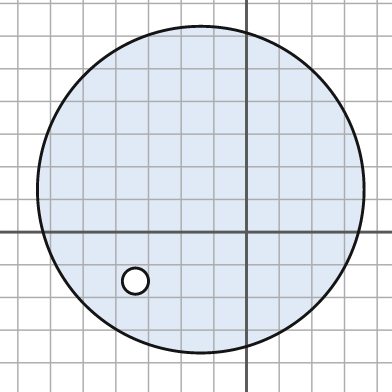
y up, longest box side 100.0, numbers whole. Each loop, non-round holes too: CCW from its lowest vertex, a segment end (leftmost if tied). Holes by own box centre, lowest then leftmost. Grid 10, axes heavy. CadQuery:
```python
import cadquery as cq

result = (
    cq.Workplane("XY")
    .moveTo(-14.0, 13.0)
    .circle(50.0)
    .moveTo(-34.0, -15.0)
    .circle(4.0)
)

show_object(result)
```